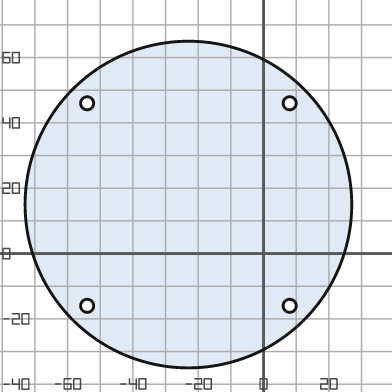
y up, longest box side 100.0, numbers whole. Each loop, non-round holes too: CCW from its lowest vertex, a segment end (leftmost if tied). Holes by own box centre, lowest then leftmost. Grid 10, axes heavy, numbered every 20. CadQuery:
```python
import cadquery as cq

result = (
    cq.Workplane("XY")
    .moveTo(-23.0, 15.0)
    .circle(50.0)
    .moveTo(-54.0, -16.0)
    .circle(2.0)
    .moveTo(8.0, -16.0)
    .circle(2.0)
    .moveTo(-54.0, 46.0)
    .circle(2.0)
    .moveTo(8.0, 46.0)
    .circle(2.0)
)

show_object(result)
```